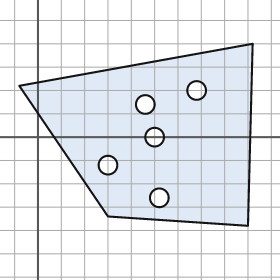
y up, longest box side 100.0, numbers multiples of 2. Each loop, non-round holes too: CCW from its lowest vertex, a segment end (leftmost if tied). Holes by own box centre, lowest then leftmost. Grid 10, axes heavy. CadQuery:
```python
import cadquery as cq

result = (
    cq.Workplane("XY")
    .moveTo(90.0, -38.0)
    .lineTo(92.0, 40.0)
    .lineTo(-8.0, 22.0)
    .lineTo(30.0, -34.0)
    .close()
    .moveTo(52.0, -26.0)
    .circle(4.0)
    .moveTo(30.0, -12.0)
    .circle(4.0)
    .moveTo(50.0, 0.0)
    .circle(4.0)
    .moveTo(46.0, 14.0)
    .circle(4.0)
    .moveTo(68.0, 20.0)
    .circle(4.0)
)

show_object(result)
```